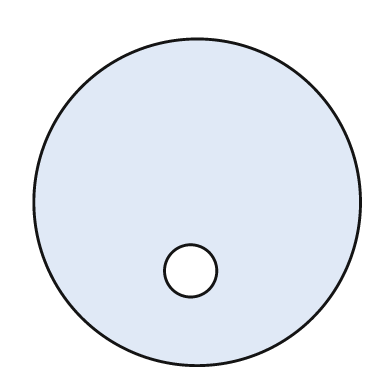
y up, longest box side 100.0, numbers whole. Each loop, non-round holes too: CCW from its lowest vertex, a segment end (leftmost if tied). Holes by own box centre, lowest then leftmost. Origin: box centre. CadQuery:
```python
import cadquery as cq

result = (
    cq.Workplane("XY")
    .moveTo(0.0, 0.0)
    .circle(50.0)
    .moveTo(-2.0, -21.0)
    .circle(8.0)
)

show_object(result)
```